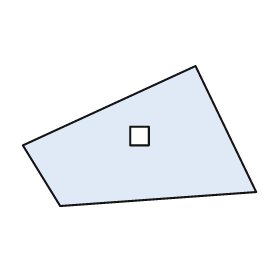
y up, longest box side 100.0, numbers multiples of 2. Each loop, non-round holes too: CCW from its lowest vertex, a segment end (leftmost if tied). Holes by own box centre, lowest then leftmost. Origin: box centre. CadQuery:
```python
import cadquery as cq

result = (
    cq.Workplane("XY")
    .moveTo(-34.0, -30.0)
    .lineTo(50.0, -24.0)
    .lineTo(24.0, 30.0)
    .lineTo(-50.0, -4.0)
    .close()
    .moveTo(-4.0, -4.0)
    .lineTo(4.0, -4.0)
    .lineTo(4.0, 4.0)
    .lineTo(-4.0, 4.0)
    .close()
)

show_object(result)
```